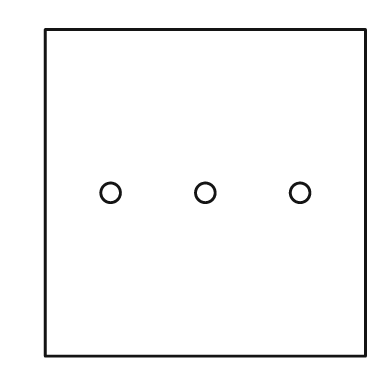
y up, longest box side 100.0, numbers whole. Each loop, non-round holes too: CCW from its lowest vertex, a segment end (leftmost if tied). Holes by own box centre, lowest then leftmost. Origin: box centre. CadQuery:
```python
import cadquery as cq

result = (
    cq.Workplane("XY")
    .moveTo(-49.0, -50.0)
    .lineTo(49.0, -50.0)
    .lineTo(49.0, 50.0)
    .lineTo(-49.0, 50.0)
    .close()
    .moveTo(-29.0, 0.0)
    .circle(3.0)
    .moveTo(0.0, 0.0)
    .circle(3.0)
    .moveTo(29.0, 0.0)
    .circle(3.0)
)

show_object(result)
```